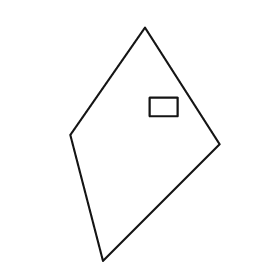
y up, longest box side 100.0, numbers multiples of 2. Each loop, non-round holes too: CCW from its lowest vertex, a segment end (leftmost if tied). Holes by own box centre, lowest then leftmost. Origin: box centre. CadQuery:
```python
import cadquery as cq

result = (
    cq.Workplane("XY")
    .moveTo(-18.0, -50.0)
    .lineTo(32.0, 0.0)
    .lineTo(0.0, 50.0)
    .lineTo(-32.0, 4.0)
    .close()
    .moveTo(2.0, 12.0)
    .lineTo(14.0, 12.0)
    .lineTo(14.0, 20.0)
    .lineTo(2.0, 20.0)
    .close()
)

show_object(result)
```